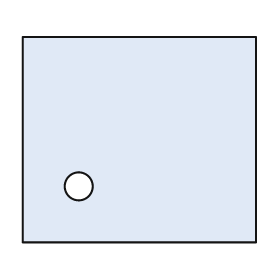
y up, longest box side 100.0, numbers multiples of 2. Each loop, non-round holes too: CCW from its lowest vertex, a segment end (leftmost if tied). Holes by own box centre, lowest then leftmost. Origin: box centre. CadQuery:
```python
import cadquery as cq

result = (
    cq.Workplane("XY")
    .moveTo(-50.0, -44.0)
    .lineTo(50.0, -44.0)
    .lineTo(50.0, 44.0)
    .lineTo(-50.0, 44.0)
    .close()
    .moveTo(-26.0, -20.0)
    .circle(6.0)
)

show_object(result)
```